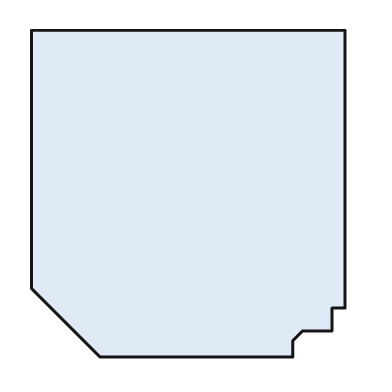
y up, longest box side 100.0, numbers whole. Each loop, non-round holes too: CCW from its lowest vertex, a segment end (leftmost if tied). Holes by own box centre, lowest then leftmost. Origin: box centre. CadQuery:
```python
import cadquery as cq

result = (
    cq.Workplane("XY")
    .moveTo(-27.0, -50.0)
    .lineTo(32.0, -50.0)
    .lineTo(32.0, -45.0)
    .lineTo(35.0, -42.0)
    .lineTo(44.0, -42.0)
    .lineTo(44.0, -35.0)
    .lineTo(48.0, -35.0)
    .lineTo(48.0, 50.0)
    .lineTo(-48.0, 50.0)
    .lineTo(-48.0, -29.0)
    .close()
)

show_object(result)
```